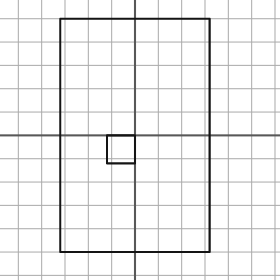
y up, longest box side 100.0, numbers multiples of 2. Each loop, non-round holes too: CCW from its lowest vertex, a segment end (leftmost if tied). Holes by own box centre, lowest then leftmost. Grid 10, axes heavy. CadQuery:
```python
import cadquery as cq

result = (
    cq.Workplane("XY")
    .moveTo(-32.0, -50.0)
    .lineTo(32.0, -50.0)
    .lineTo(32.0, 50.0)
    .lineTo(-32.0, 50.0)
    .close()
    .moveTo(-12.0, -12.0)
    .lineTo(0.0, -12.0)
    .lineTo(0.0, 0.0)
    .lineTo(-12.0, 0.0)
    .close()
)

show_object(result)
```